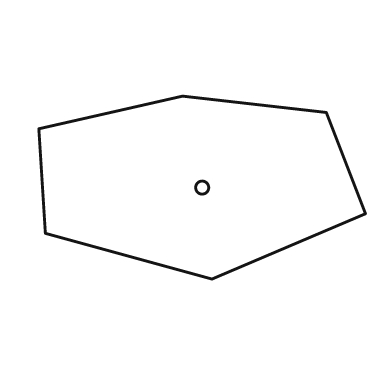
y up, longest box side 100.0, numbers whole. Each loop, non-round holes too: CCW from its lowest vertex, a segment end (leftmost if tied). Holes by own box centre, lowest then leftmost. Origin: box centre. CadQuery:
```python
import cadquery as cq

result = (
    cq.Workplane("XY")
    .moveTo(3.0, -28.0)
    .lineTo(50.0, -8.0)
    .lineTo(38.0, 23.0)
    .lineTo(-6.0, 28.0)
    .lineTo(-50.0, 18.0)
    .lineTo(-48.0, -14.0)
    .close()
    .moveTo(0.0, 0.0)
    .circle(2.0)
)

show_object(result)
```